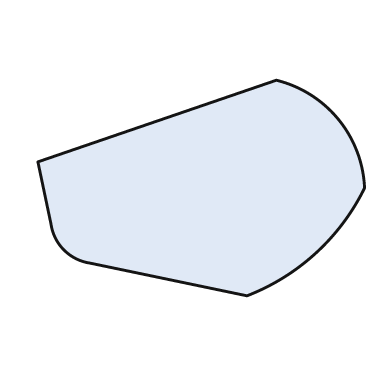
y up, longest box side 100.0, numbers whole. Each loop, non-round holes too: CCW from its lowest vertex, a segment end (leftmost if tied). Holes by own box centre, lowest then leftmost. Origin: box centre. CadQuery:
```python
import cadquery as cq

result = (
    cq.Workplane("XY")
    .moveTo(14.0, -33.0)
    .threePointArc((35.0, -20.0), (50.0, 0.0))
    .threePointArc((42.0, 21.0), (23.0, 33.0))
    .lineTo(-50.0, 8.0)
    .lineTo(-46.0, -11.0)
    .threePointArc((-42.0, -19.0), (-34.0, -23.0))
    .close()
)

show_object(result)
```